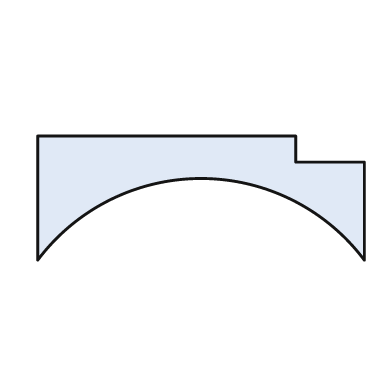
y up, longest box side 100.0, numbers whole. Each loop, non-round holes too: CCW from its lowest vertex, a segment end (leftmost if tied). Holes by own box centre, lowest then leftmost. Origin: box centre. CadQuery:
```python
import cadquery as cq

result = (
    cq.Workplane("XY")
    .moveTo(-50.0, -19.0)
    .threePointArc((0.0, 6.0), (50.0, -19.0))
    .lineTo(50.0, 11.0)
    .lineTo(29.0, 11.0)
    .lineTo(29.0, 19.0)
    .lineTo(-50.0, 19.0)
    .close()
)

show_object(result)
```